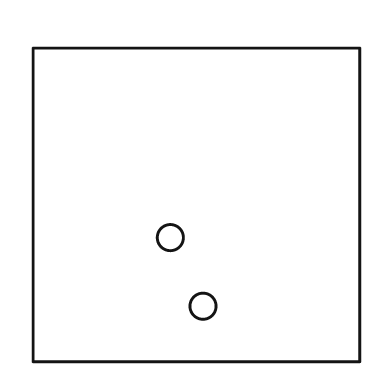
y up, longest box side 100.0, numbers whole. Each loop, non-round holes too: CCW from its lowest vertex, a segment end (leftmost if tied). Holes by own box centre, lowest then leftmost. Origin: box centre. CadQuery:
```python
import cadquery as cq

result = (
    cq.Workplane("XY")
    .moveTo(-50.0, -48.0)
    .lineTo(50.0, -48.0)
    .lineTo(50.0, 48.0)
    .lineTo(-50.0, 48.0)
    .close()
    .moveTo(2.0, -31.0)
    .circle(4.0)
    .moveTo(-8.0, -10.0)
    .circle(4.0)
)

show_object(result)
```